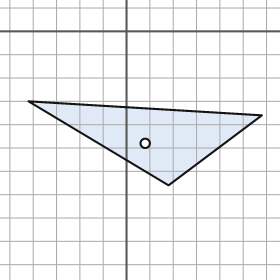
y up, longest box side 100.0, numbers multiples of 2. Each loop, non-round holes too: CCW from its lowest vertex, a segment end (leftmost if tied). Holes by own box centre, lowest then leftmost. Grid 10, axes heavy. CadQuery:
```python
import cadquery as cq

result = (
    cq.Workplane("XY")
    .moveTo(18.0, -66.0)
    .lineTo(58.0, -36.0)
    .lineTo(-42.0, -30.0)
    .close()
    .moveTo(8.0, -48.0)
    .circle(2.0)
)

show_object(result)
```